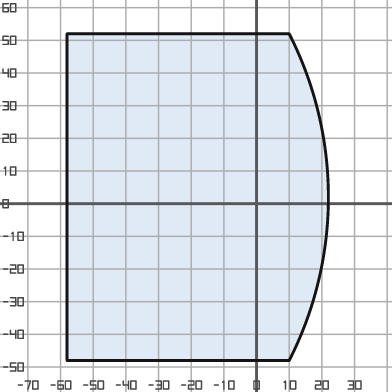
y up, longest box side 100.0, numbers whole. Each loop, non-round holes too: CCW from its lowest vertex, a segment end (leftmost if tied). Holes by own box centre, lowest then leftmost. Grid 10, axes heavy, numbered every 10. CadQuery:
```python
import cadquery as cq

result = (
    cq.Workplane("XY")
    .moveTo(-58.0, -48.0)
    .lineTo(10.0, -48.0)
    .threePointArc((22.0, 2.0), (10.0, 52.0))
    .lineTo(-58.0, 52.0)
    .close()
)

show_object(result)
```